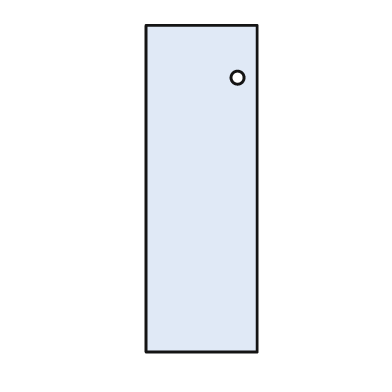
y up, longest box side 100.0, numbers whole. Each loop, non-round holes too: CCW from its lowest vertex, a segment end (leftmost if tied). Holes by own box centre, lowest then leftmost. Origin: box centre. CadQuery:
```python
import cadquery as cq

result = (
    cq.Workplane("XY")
    .moveTo(-17.0, -50.0)
    .lineTo(17.0, -50.0)
    .lineTo(17.0, 50.0)
    .lineTo(-17.0, 50.0)
    .close()
    .moveTo(11.0, 34.0)
    .circle(2.0)
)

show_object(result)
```